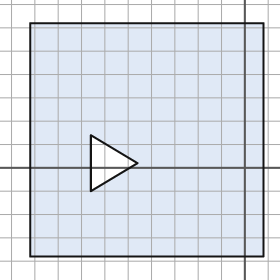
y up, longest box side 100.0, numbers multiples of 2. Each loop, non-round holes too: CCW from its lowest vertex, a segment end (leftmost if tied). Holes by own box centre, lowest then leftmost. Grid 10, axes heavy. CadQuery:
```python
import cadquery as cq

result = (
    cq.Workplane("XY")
    .moveTo(-92.0, -38.0)
    .lineTo(8.0, -38.0)
    .lineTo(8.0, 62.0)
    .lineTo(-92.0, 62.0)
    .close()
    .moveTo(-66.0, -10.0)
    .lineTo(-46.0, 2.0)
    .lineTo(-66.0, 14.0)
    .close()
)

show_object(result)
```